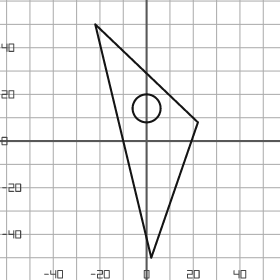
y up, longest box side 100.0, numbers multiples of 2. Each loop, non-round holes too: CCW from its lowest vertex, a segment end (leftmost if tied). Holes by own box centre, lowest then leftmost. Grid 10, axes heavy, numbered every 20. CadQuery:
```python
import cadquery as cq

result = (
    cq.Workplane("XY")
    .moveTo(2.0, -50.0)
    .lineTo(22.0, 8.0)
    .lineTo(-22.0, 50.0)
    .close()
    .moveTo(0.0, 14.0)
    .circle(6.0)
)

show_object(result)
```